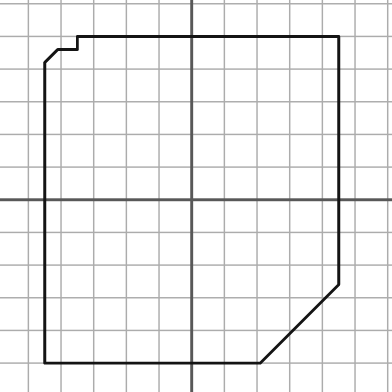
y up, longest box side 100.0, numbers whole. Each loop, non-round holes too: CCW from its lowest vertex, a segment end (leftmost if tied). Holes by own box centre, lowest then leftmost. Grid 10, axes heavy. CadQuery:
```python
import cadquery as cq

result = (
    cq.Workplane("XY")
    .moveTo(-45.0, -50.0)
    .lineTo(21.0, -50.0)
    .lineTo(45.0, -26.0)
    .lineTo(45.0, 50.0)
    .lineTo(-35.0, 50.0)
    .lineTo(-35.0, 46.0)
    .lineTo(-41.0, 46.0)
    .lineTo(-45.0, 42.0)
    .close()
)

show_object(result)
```